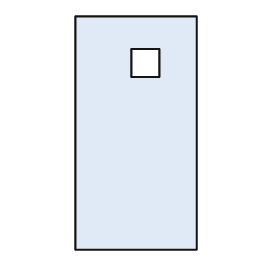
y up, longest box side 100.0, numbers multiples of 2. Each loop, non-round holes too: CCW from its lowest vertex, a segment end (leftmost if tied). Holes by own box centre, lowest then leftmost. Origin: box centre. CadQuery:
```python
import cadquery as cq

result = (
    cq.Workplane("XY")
    .moveTo(-26.0, -50.0)
    .lineTo(26.0, -50.0)
    .lineTo(26.0, 50.0)
    .lineTo(-26.0, 50.0)
    .close()
    .moveTo(-2.0, 24.0)
    .lineTo(10.0, 24.0)
    .lineTo(10.0, 36.0)
    .lineTo(-2.0, 36.0)
    .close()
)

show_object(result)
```